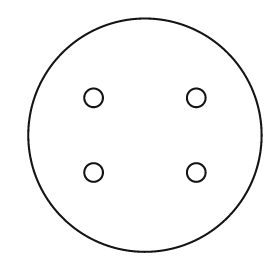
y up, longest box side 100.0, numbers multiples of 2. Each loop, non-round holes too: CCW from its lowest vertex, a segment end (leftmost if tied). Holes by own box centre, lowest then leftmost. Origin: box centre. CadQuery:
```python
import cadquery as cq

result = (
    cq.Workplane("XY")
    .moveTo(0.0, 0.0)
    .circle(50.0)
    .moveTo(-22.0, -16.0)
    .circle(4.0)
    .moveTo(22.0, -16.0)
    .circle(4.0)
    .moveTo(-22.0, 16.0)
    .circle(4.0)
    .moveTo(22.0, 16.0)
    .circle(4.0)
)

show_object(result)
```